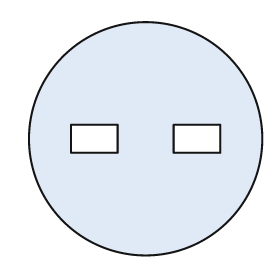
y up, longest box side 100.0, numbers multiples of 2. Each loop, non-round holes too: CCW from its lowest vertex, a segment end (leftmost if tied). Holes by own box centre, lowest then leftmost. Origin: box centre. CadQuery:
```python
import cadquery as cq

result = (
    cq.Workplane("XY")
    .moveTo(0.0, 0.0)
    .circle(50.0)
    .moveTo(-32.0, -6.0)
    .lineTo(-12.0, -6.0)
    .lineTo(-12.0, 6.0)
    .lineTo(-32.0, 6.0)
    .close()
    .moveTo(12.0, -6.0)
    .lineTo(32.0, -6.0)
    .lineTo(32.0, 6.0)
    .lineTo(12.0, 6.0)
    .close()
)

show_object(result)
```